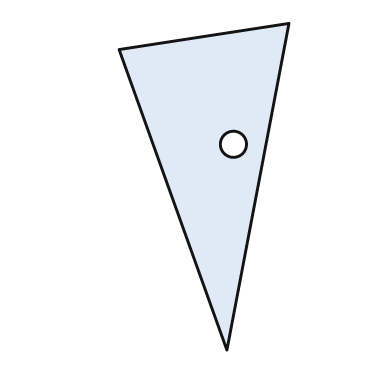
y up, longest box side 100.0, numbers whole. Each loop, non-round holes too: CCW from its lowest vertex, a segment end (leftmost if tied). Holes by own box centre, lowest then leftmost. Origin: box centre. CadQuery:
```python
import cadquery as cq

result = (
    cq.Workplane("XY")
    .moveTo(7.0, -50.0)
    .lineTo(26.0, 50.0)
    .lineTo(-26.0, 42.0)
    .close()
    .moveTo(9.0, 13.0)
    .circle(4.0)
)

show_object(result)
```